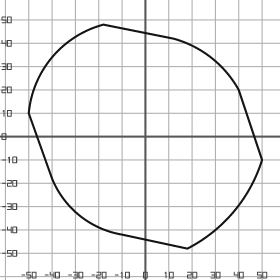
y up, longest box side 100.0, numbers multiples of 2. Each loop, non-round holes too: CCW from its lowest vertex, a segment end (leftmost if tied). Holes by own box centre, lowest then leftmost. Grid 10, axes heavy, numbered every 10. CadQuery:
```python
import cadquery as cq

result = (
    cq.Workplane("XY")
    .moveTo(18.0, -48.0)
    .threePointArc((38.0, -32.0), (50.0, -10.0))
    .lineTo(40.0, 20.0)
    .threePointArc((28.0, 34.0), (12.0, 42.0))
    .lineTo(-18.0, 48.0)
    .threePointArc((-40.0, 34.0), (-50.0, 10.0))
    .lineTo(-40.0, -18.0)
    .threePointArc((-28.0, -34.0), (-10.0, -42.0))
    .close()
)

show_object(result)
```